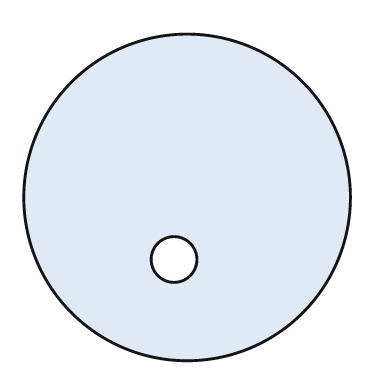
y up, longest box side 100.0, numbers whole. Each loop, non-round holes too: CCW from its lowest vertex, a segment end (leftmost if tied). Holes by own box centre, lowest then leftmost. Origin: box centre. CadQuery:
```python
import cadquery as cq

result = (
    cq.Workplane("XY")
    .moveTo(0.0, 0.0)
    .circle(50.0)
    .moveTo(-4.0, -19.0)
    .circle(7.0)
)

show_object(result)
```